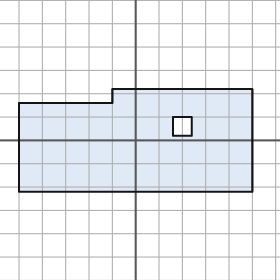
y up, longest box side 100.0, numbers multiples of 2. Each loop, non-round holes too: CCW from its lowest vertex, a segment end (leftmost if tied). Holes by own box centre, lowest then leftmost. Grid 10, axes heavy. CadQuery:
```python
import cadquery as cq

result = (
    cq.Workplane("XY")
    .moveTo(-50.0, -22.0)
    .lineTo(50.0, -22.0)
    .lineTo(50.0, 22.0)
    .lineTo(-10.0, 22.0)
    .lineTo(-10.0, 16.0)
    .lineTo(-50.0, 16.0)
    .close()
    .moveTo(16.0, 2.0)
    .lineTo(24.0, 2.0)
    .lineTo(24.0, 10.0)
    .lineTo(16.0, 10.0)
    .close()
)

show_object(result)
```